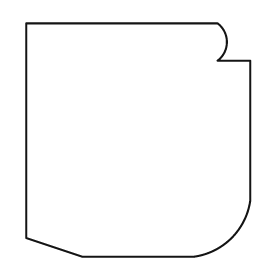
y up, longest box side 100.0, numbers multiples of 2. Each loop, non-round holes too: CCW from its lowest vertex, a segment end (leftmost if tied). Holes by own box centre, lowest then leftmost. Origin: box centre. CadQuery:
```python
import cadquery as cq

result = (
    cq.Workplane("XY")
    .moveTo(-24.0, -50.0)
    .lineTo(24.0, -50.0)
    .threePointArc((40.0, -42.0), (48.0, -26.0))
    .lineTo(48.0, 34.0)
    .lineTo(34.0, 34.0)
    .threePointArc((38.0, 42.0), (34.0, 50.0))
    .lineTo(-48.0, 50.0)
    .lineTo(-48.0, -42.0)
    .close()
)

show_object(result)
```